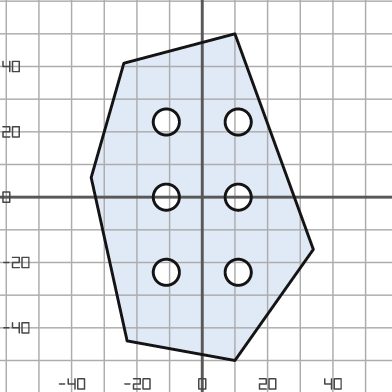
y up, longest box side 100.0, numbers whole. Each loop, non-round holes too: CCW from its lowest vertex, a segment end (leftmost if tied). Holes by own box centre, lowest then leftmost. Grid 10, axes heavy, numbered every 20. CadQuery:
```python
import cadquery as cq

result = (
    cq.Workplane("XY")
    .moveTo(10.0, -50.0)
    .lineTo(34.0, -16.0)
    .lineTo(10.0, 50.0)
    .lineTo(-24.0, 41.0)
    .lineTo(-34.0, 6.0)
    .lineTo(-23.0, -44.0)
    .close()
    .moveTo(-11.0, -23.0)
    .circle(4.0)
    .moveTo(11.0, -23.0)
    .circle(4.0)
    .moveTo(-11.0, 0.0)
    .circle(4.0)
    .moveTo(11.0, 0.0)
    .circle(4.0)
    .moveTo(-11.0, 23.0)
    .circle(4.0)
    .moveTo(11.0, 23.0)
    .circle(4.0)
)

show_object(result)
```